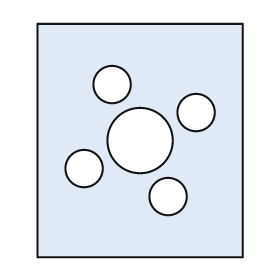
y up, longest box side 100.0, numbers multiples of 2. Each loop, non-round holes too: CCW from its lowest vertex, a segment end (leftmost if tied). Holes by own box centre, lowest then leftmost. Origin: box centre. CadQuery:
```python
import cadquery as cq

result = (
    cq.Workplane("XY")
    .moveTo(-44.0, -50.0)
    .lineTo(44.0, -50.0)
    .lineTo(44.0, 50.0)
    .lineTo(-44.0, 50.0)
    .close()
    .moveTo(12.0, -24.0)
    .circle(8.0)
    .moveTo(-24.0, -12.0)
    .circle(8.0)
    .moveTo(0.0, 0.0)
    .circle(14.0)
    .moveTo(24.0, 12.0)
    .circle(8.0)
    .moveTo(-12.0, 24.0)
    .circle(8.0)
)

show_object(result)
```